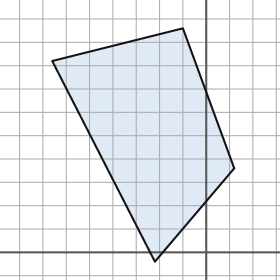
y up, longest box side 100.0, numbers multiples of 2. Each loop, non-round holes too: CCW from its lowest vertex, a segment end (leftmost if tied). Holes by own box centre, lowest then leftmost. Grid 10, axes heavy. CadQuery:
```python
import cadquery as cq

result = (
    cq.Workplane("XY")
    .moveTo(-22.0, -4.0)
    .lineTo(12.0, 36.0)
    .lineTo(-10.0, 96.0)
    .lineTo(-66.0, 82.0)
    .close()
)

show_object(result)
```